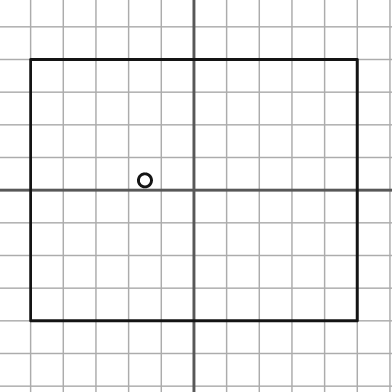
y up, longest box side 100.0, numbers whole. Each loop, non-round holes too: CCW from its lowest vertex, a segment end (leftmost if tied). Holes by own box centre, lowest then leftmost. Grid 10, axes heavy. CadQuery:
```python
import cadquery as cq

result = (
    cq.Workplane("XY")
    .moveTo(-50.0, -40.0)
    .lineTo(50.0, -40.0)
    .lineTo(50.0, 40.0)
    .lineTo(-50.0, 40.0)
    .close()
    .moveTo(-15.0, 3.0)
    .circle(2.0)
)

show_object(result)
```